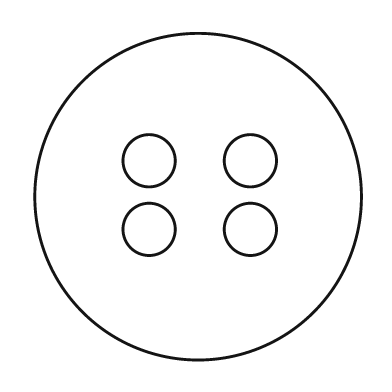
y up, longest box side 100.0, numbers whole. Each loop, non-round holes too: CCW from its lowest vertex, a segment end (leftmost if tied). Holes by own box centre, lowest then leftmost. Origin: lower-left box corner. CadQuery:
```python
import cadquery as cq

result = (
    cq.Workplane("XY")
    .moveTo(50.0, 50.0)
    .circle(50.0)
    .moveTo(35.0, 40.0)
    .circle(8.0)
    .moveTo(66.0, 40.0)
    .circle(8.0)
    .moveTo(35.0, 61.0)
    .circle(8.0)
    .moveTo(66.0, 61.0)
    .circle(8.0)
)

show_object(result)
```